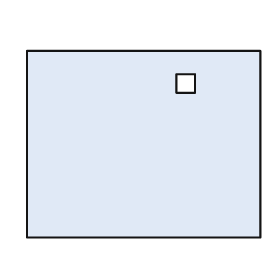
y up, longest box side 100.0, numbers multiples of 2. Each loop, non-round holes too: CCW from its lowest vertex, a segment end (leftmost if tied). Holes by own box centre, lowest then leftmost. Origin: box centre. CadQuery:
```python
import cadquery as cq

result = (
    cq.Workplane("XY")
    .moveTo(-50.0, -40.0)
    .lineTo(50.0, -40.0)
    .lineTo(50.0, 40.0)
    .lineTo(-50.0, 40.0)
    .close()
    .moveTo(14.0, 22.0)
    .lineTo(22.0, 22.0)
    .lineTo(22.0, 30.0)
    .lineTo(14.0, 30.0)
    .close()
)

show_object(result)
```